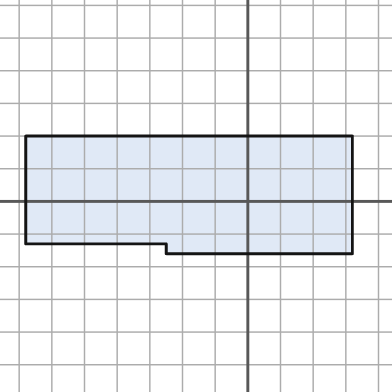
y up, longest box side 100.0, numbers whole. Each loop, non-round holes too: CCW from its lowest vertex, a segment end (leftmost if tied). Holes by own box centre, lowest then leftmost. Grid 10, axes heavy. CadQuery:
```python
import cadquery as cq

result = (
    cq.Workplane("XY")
    .moveTo(-25.0, -16.0)
    .lineTo(32.0, -16.0)
    .lineTo(32.0, 20.0)
    .lineTo(-68.0, 20.0)
    .lineTo(-68.0, -13.0)
    .lineTo(-25.0, -13.0)
    .close()
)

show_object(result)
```